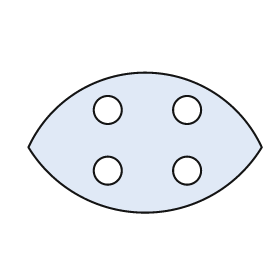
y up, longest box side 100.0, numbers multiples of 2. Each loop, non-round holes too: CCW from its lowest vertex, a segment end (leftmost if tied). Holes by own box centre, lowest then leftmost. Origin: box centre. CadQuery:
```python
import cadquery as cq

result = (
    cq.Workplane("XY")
    .moveTo(-50.0, -2.0)
    .threePointArc((0.0, -30.0), (50.0, -2.0))
    .threePointArc((0.0, 30.0), (-50.0, -2.0))
    .close()
    .moveTo(-16.0, -12.0)
    .circle(6.0)
    .moveTo(18.0, -12.0)
    .circle(6.0)
    .moveTo(-16.0, 14.0)
    .circle(6.0)
    .moveTo(18.0, 14.0)
    .circle(6.0)
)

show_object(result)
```